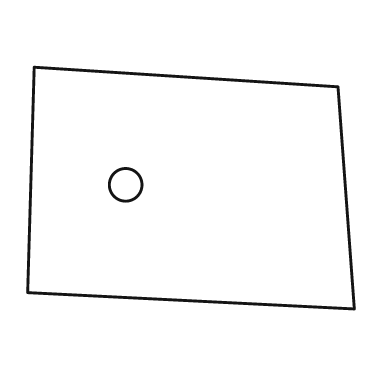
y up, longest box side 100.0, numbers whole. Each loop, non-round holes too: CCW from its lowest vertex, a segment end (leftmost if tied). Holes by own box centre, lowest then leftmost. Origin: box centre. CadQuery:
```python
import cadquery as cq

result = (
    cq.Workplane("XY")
    .moveTo(50.0, -37.0)
    .lineTo(45.0, 31.0)
    .lineTo(-48.0, 37.0)
    .lineTo(-50.0, -32.0)
    .close()
    .moveTo(-20.0, 1.0)
    .circle(5.0)
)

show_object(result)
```